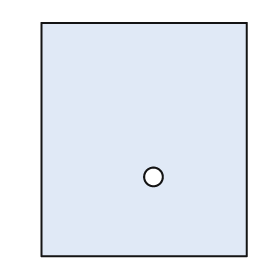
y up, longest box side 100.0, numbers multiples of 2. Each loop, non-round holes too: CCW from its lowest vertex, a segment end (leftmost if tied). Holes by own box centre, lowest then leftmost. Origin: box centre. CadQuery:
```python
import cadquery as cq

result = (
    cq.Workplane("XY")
    .moveTo(-44.0, -50.0)
    .lineTo(44.0, -50.0)
    .lineTo(44.0, 50.0)
    .lineTo(-44.0, 50.0)
    .close()
    .moveTo(4.0, -16.0)
    .circle(4.0)
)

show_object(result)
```